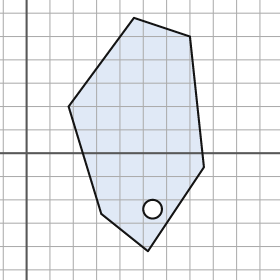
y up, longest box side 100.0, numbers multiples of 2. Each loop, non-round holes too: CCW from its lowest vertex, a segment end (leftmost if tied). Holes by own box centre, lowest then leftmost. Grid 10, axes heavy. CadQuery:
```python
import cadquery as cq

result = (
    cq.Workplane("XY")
    .moveTo(52.0, -42.0)
    .lineTo(76.0, -6.0)
    .lineTo(70.0, 50.0)
    .lineTo(46.0, 58.0)
    .lineTo(18.0, 20.0)
    .lineTo(32.0, -26.0)
    .close()
    .moveTo(54.0, -24.0)
    .circle(4.0)
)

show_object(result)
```